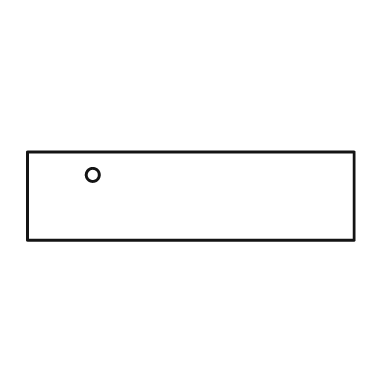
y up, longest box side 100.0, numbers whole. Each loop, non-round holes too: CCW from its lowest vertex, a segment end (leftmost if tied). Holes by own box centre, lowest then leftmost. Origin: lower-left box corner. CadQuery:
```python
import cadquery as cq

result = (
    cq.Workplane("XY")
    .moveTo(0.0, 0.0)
    .lineTo(100.0, 0.0)
    .lineTo(100.0, 27.0)
    .lineTo(0.0, 27.0)
    .close()
    .moveTo(20.0, 20.0)
    .circle(2.0)
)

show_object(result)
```